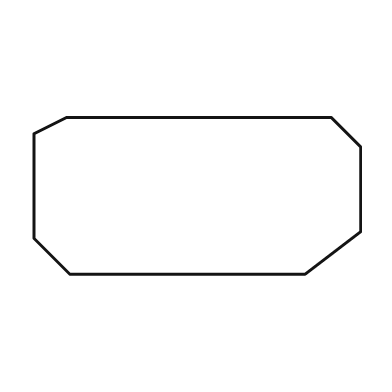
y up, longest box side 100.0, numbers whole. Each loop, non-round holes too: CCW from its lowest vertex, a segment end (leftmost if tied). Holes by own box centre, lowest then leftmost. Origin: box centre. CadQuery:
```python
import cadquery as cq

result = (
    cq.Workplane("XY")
    .moveTo(-39.0, -24.0)
    .lineTo(33.0, -24.0)
    .lineTo(50.0, -11.0)
    .lineTo(50.0, 15.0)
    .lineTo(41.0, 24.0)
    .lineTo(-40.0, 24.0)
    .lineTo(-50.0, 19.0)
    .lineTo(-50.0, -13.0)
    .close()
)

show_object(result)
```